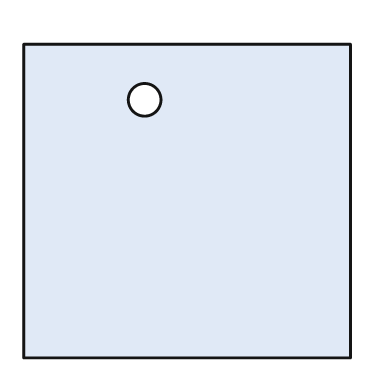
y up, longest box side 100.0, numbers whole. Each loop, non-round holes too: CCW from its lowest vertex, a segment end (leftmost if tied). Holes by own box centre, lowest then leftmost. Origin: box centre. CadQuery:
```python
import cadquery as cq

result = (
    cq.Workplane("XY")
    .moveTo(-50.0, -48.0)
    .lineTo(50.0, -48.0)
    .lineTo(50.0, 48.0)
    .lineTo(-50.0, 48.0)
    .close()
    .moveTo(-13.0, 31.0)
    .circle(5.0)
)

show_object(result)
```